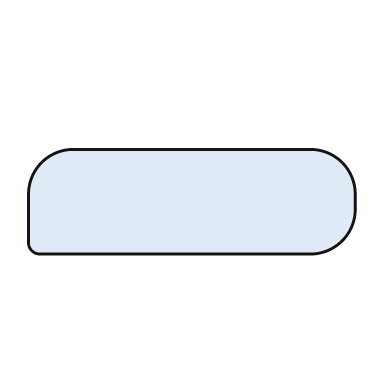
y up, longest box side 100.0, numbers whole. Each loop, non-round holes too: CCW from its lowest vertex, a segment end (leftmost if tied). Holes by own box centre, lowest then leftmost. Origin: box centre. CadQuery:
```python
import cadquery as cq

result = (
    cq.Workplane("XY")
    .moveTo(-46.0, -16.0)
    .lineTo(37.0, -16.0)
    .threePointArc((46.0, -12.0), (50.0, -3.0))
    .lineTo(50.0, 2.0)
    .threePointArc((46.0, 12.0), (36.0, 16.0))
    .lineTo(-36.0, 16.0)
    .threePointArc((-46.0, 12.0), (-50.0, 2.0))
    .lineTo(-50.0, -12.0)
    .threePointArc((-49.0, -15.0), (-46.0, -16.0))
    .close()
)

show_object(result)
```